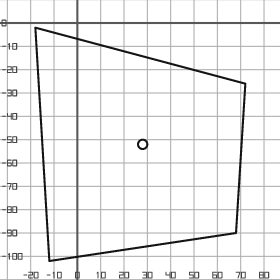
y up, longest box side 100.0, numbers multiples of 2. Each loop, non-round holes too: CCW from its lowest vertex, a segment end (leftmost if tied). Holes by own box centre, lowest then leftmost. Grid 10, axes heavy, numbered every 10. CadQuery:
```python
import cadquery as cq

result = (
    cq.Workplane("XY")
    .moveTo(-12.0, -102.0)
    .lineTo(68.0, -90.0)
    .lineTo(72.0, -26.0)
    .lineTo(-18.0, -2.0)
    .close()
    .moveTo(28.0, -52.0)
    .circle(2.0)
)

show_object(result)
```